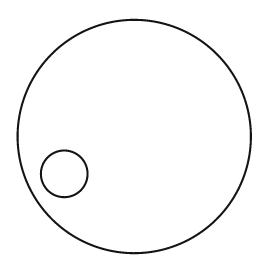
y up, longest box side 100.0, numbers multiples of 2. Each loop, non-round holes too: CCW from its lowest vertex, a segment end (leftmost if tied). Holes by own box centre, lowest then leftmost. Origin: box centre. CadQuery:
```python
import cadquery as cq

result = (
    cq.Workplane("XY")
    .moveTo(0.0, 0.0)
    .circle(50.0)
    .moveTo(-30.0, -16.0)
    .circle(10.0)
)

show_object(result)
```